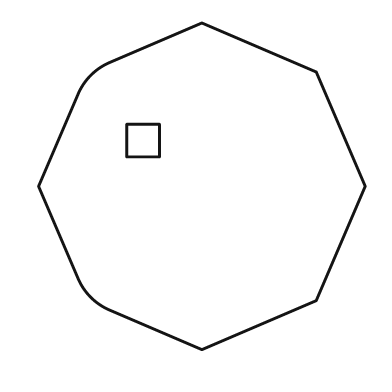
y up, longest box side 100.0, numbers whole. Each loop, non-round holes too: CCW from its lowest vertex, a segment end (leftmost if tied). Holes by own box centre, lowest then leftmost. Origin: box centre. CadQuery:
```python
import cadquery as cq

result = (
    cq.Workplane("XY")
    .moveTo(0.0, -50.0)
    .lineTo(35.0, -35.0)
    .lineTo(50.0, 0.0)
    .lineTo(35.0, 35.0)
    .lineTo(0.0, 50.0)
    .lineTo(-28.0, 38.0)
    .threePointArc((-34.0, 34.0), (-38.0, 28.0))
    .lineTo(-50.0, 0.0)
    .lineTo(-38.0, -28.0)
    .threePointArc((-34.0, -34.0), (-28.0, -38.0))
    .close()
    .moveTo(-23.0, 9.0)
    .lineTo(-13.0, 9.0)
    .lineTo(-13.0, 19.0)
    .lineTo(-23.0, 19.0)
    .close()
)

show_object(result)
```